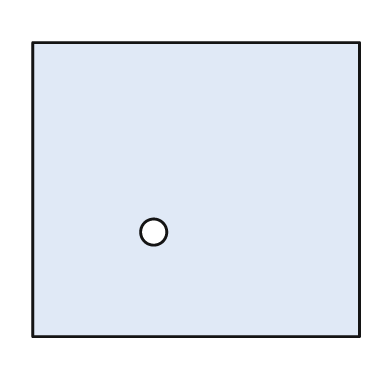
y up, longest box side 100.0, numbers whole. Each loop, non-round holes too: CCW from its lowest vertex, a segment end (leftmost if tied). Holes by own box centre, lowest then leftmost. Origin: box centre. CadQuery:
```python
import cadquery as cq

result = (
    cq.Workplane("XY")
    .moveTo(-50.0, -45.0)
    .lineTo(50.0, -45.0)
    .lineTo(50.0, 45.0)
    .lineTo(-50.0, 45.0)
    .close()
    .moveTo(-13.0, -13.0)
    .circle(4.0)
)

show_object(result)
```